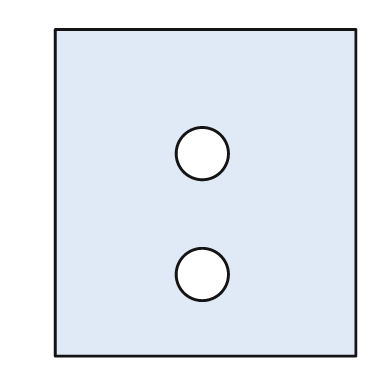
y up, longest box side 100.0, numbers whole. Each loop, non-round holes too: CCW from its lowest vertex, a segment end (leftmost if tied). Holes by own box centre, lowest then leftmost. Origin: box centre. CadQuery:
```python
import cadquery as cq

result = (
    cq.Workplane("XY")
    .moveTo(-46.0, -50.0)
    .lineTo(46.0, -50.0)
    .lineTo(46.0, 50.0)
    .lineTo(-46.0, 50.0)
    .close()
    .moveTo(-1.0, -25.0)
    .circle(8.0)
    .moveTo(-1.0, 12.0)
    .circle(8.0)
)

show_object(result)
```